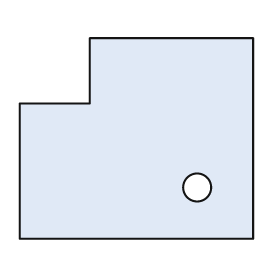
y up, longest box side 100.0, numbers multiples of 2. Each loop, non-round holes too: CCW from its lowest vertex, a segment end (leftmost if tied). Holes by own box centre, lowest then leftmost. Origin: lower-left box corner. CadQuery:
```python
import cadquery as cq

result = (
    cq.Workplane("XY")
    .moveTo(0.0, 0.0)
    .lineTo(100.0, 0.0)
    .lineTo(100.0, 86.0)
    .lineTo(30.0, 86.0)
    .lineTo(30.0, 58.0)
    .lineTo(0.0, 58.0)
    .close()
    .moveTo(76.0, 22.0)
    .circle(6.0)
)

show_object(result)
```